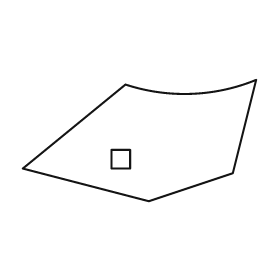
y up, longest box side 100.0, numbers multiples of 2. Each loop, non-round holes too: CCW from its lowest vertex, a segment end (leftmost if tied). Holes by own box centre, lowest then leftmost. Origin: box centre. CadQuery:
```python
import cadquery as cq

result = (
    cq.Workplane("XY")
    .moveTo(4.0, -26.0)
    .lineTo(40.0, -14.0)
    .lineTo(50.0, 26.0)
    .threePointArc((22.0, 20.0), (-6.0, 24.0))
    .lineTo(-50.0, -12.0)
    .close()
    .moveTo(-12.0, -12.0)
    .lineTo(-4.0, -12.0)
    .lineTo(-4.0, -4.0)
    .lineTo(-12.0, -4.0)
    .close()
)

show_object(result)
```